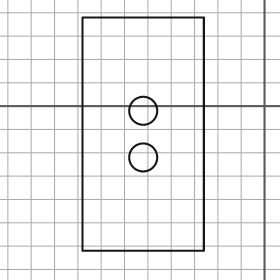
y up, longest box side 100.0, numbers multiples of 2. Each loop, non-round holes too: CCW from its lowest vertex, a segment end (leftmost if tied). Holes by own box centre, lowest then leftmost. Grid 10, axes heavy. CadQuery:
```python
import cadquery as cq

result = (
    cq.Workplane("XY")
    .moveTo(-78.0, -62.0)
    .lineTo(-26.0, -62.0)
    .lineTo(-26.0, 38.0)
    .lineTo(-78.0, 38.0)
    .close()
    .moveTo(-52.0, -22.0)
    .circle(6.0)
    .moveTo(-52.0, -2.0)
    .circle(6.0)
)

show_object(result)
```